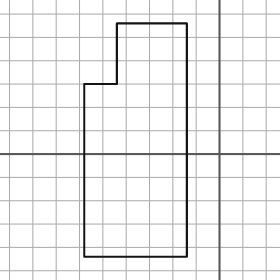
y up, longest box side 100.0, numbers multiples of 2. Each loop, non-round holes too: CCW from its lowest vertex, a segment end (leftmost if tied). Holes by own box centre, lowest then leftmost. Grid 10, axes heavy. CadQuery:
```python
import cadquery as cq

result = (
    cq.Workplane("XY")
    .moveTo(-58.0, -44.0)
    .lineTo(-14.0, -44.0)
    .lineTo(-14.0, 56.0)
    .lineTo(-44.0, 56.0)
    .lineTo(-44.0, 30.0)
    .lineTo(-58.0, 30.0)
    .close()
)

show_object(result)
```